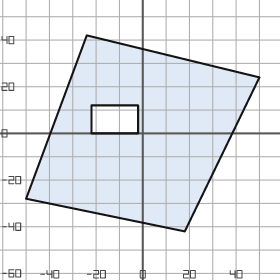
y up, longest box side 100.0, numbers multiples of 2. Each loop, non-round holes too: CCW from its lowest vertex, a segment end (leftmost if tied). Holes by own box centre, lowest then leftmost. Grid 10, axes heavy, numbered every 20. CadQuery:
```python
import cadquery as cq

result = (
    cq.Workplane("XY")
    .moveTo(18.0, -42.0)
    .lineTo(50.0, 24.0)
    .lineTo(-24.0, 42.0)
    .lineTo(-50.0, -28.0)
    .close()
    .moveTo(-22.0, 0.0)
    .lineTo(-2.0, 0.0)
    .lineTo(-2.0, 12.0)
    .lineTo(-22.0, 12.0)
    .close()
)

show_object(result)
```